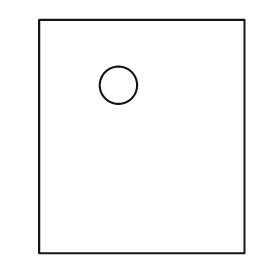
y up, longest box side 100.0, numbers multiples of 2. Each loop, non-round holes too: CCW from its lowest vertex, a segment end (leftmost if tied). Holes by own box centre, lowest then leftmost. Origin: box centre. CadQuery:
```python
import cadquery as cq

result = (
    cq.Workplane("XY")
    .moveTo(-44.0, -50.0)
    .lineTo(44.0, -50.0)
    .lineTo(44.0, 50.0)
    .lineTo(-44.0, 50.0)
    .close()
    .moveTo(-10.0, 22.0)
    .circle(8.0)
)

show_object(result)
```